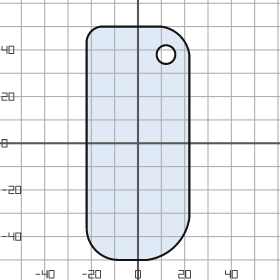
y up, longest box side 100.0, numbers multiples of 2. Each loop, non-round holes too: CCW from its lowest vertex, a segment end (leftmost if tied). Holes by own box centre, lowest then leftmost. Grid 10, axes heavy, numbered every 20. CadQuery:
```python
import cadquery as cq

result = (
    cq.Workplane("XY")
    .moveTo(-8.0, -50.0)
    .lineTo(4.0, -50.0)
    .threePointArc((16.0, -44.0), (22.0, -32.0))
    .lineTo(22.0, 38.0)
    .threePointArc((18.0, 46.0), (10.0, 50.0))
    .lineTo(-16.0, 50.0)
    .threePointArc((-20.0, 48.0), (-22.0, 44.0))
    .lineTo(-22.0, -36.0)
    .threePointArc((-18.0, -46.0), (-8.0, -50.0))
    .close()
    .moveTo(12.0, 38.0)
    .circle(4.0)
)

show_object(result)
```